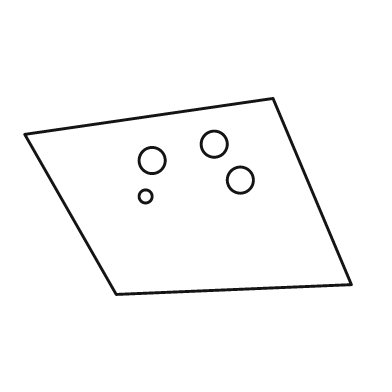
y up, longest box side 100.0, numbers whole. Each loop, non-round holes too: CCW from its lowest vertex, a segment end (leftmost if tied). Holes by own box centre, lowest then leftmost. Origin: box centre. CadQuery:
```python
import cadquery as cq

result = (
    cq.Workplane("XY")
    .moveTo(-22.0, -30.0)
    .lineTo(50.0, -27.0)
    .lineTo(26.0, 30.0)
    .lineTo(-50.0, 19.0)
    .close()
    .moveTo(-13.0, 0.0)
    .circle(2.0)
    .moveTo(16.0, 5.0)
    .circle(4.0)
    .moveTo(-11.0, 11.0)
    .circle(4.0)
    .moveTo(8.0, 16.0)
    .circle(4.0)
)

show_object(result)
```